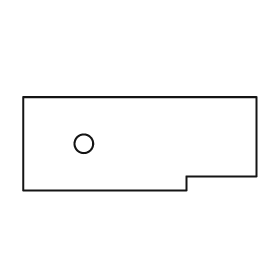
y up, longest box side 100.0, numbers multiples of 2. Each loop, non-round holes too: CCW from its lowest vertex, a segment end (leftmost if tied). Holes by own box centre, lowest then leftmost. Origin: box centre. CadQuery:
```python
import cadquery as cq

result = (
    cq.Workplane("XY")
    .moveTo(-50.0, -20.0)
    .lineTo(20.0, -20.0)
    .lineTo(20.0, -14.0)
    .lineTo(50.0, -14.0)
    .lineTo(50.0, 20.0)
    .lineTo(-50.0, 20.0)
    .close()
    .moveTo(-24.0, 0.0)
    .circle(4.0)
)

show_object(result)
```